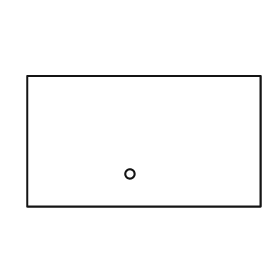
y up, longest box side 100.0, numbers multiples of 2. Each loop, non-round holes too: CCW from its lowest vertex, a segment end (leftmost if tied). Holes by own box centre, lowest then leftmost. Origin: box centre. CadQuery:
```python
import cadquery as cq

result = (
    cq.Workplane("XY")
    .moveTo(-50.0, -28.0)
    .lineTo(50.0, -28.0)
    .lineTo(50.0, 28.0)
    .lineTo(-50.0, 28.0)
    .close()
    .moveTo(-6.0, -14.0)
    .circle(2.0)
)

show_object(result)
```